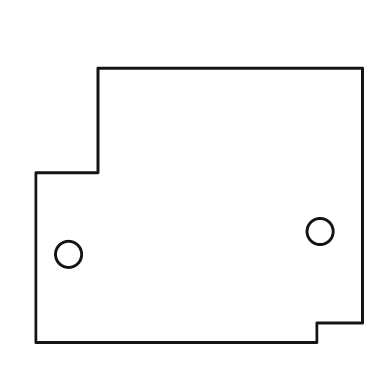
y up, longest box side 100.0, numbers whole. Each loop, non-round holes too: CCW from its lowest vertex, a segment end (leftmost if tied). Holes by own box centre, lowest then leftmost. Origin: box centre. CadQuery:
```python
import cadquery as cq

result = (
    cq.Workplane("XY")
    .moveTo(-50.0, -42.0)
    .lineTo(36.0, -42.0)
    .lineTo(36.0, -36.0)
    .lineTo(50.0, -36.0)
    .lineTo(50.0, 42.0)
    .lineTo(-31.0, 42.0)
    .lineTo(-31.0, 10.0)
    .lineTo(-50.0, 10.0)
    .close()
    .moveTo(-40.0, -15.0)
    .circle(4.0)
    .moveTo(37.0, -8.0)
    .circle(4.0)
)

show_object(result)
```